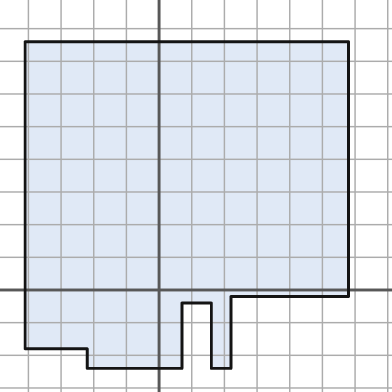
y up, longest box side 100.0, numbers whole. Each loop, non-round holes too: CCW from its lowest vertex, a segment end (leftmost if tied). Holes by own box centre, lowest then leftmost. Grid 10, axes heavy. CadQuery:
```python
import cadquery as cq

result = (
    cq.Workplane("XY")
    .moveTo(-22.0, -24.0)
    .lineTo(7.0, -24.0)
    .lineTo(7.0, -4.0)
    .lineTo(16.0, -4.0)
    .lineTo(16.0, -24.0)
    .lineTo(22.0, -24.0)
    .lineTo(22.0, -2.0)
    .lineTo(58.0, -2.0)
    .lineTo(58.0, 76.0)
    .lineTo(-41.0, 76.0)
    .lineTo(-41.0, -18.0)
    .lineTo(-22.0, -18.0)
    .close()
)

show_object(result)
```